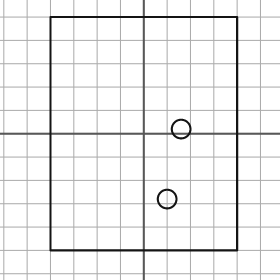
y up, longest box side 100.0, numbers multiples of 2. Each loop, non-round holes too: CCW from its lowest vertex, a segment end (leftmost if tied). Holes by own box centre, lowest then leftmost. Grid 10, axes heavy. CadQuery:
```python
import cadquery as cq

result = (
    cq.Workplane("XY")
    .moveTo(-40.0, -50.0)
    .lineTo(40.0, -50.0)
    .lineTo(40.0, 50.0)
    .lineTo(-40.0, 50.0)
    .close()
    .moveTo(10.0, -28.0)
    .circle(4.0)
    .moveTo(16.0, 2.0)
    .circle(4.0)
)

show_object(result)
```